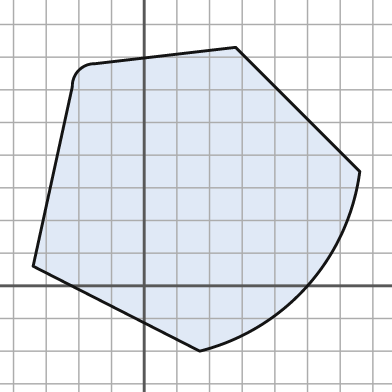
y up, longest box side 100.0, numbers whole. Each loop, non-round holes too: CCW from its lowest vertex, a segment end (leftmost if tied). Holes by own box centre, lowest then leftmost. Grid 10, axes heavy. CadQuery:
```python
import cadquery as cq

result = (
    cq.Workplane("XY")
    .moveTo(17.0, -20.0)
    .threePointArc((50.0, 0.0), (66.0, 35.0))
    .lineTo(28.0, 73.0)
    .lineTo(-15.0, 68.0)
    .threePointArc((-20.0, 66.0), (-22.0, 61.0))
    .lineTo(-34.0, 6.0)
    .close()
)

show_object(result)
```